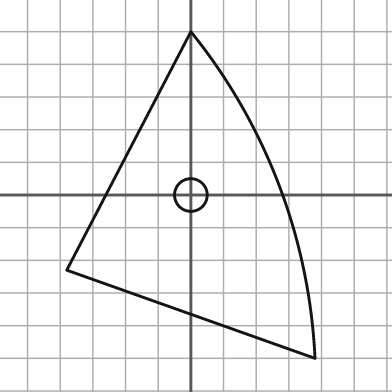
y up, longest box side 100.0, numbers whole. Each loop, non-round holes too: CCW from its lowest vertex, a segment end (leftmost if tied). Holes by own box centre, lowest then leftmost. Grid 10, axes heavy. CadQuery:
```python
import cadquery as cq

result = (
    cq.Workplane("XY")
    .moveTo(38.0, -50.0)
    .threePointArc((27.0, 3.0), (0.0, 50.0))
    .lineTo(-38.0, -23.0)
    .close()
    .moveTo(0.0, 0.0)
    .circle(5.0)
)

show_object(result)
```